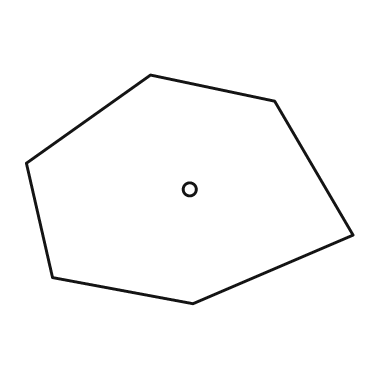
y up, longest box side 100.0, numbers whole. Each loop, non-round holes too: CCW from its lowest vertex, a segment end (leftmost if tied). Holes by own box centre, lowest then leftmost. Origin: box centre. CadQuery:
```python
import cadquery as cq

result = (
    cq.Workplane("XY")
    .moveTo(1.0, -35.0)
    .lineTo(50.0, -14.0)
    .lineTo(26.0, 27.0)
    .lineTo(-12.0, 35.0)
    .lineTo(-50.0, 8.0)
    .lineTo(-42.0, -27.0)
    .close()
    .moveTo(0.0, 0.0)
    .circle(2.0)
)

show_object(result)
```